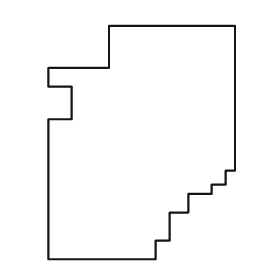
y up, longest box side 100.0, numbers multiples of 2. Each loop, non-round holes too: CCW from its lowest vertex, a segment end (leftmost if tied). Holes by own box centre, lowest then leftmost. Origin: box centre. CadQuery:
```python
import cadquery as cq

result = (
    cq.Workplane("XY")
    .moveTo(-40.0, -50.0)
    .lineTo(6.0, -50.0)
    .lineTo(6.0, -42.0)
    .lineTo(12.0, -42.0)
    .lineTo(12.0, -30.0)
    .lineTo(20.0, -30.0)
    .lineTo(20.0, -22.0)
    .lineTo(30.0, -22.0)
    .lineTo(30.0, -18.0)
    .lineTo(36.0, -18.0)
    .lineTo(36.0, -12.0)
    .lineTo(40.0, -12.0)
    .lineTo(40.0, 50.0)
    .lineTo(-14.0, 50.0)
    .lineTo(-14.0, 32.0)
    .lineTo(-40.0, 32.0)
    .lineTo(-40.0, 24.0)
    .lineTo(-30.0, 24.0)
    .lineTo(-30.0, 10.0)
    .lineTo(-40.0, 10.0)
    .close()
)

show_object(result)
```